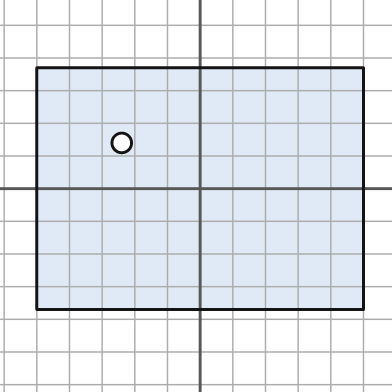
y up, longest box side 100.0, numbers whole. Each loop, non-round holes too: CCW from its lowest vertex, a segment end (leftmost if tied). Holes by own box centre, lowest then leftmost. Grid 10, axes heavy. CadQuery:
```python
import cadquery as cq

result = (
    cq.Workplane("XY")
    .moveTo(-50.0, -37.0)
    .lineTo(50.0, -37.0)
    .lineTo(50.0, 37.0)
    .lineTo(-50.0, 37.0)
    .close()
    .moveTo(-24.0, 14.0)
    .circle(3.0)
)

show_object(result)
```